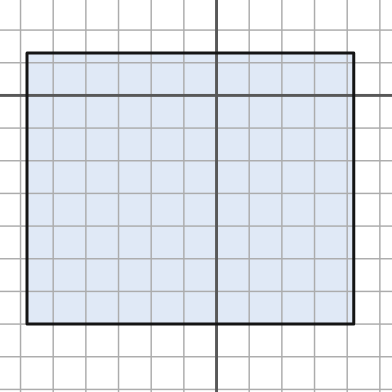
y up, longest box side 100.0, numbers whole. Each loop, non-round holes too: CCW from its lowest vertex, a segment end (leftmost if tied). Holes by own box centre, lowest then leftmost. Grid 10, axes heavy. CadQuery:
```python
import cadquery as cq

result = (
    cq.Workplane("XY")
    .moveTo(-58.0, -70.0)
    .lineTo(42.0, -70.0)
    .lineTo(42.0, 13.0)
    .lineTo(-58.0, 13.0)
    .close()
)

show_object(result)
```